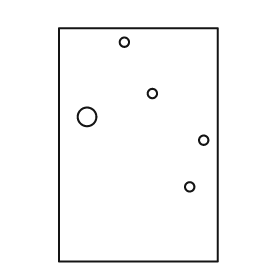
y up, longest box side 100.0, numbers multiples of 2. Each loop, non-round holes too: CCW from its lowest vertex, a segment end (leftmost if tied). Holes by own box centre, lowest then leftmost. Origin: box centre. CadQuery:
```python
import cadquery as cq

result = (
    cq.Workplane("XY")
    .moveTo(-34.0, -50.0)
    .lineTo(34.0, -50.0)
    .lineTo(34.0, 50.0)
    .lineTo(-34.0, 50.0)
    .close()
    .moveTo(22.0, -18.0)
    .circle(2.0)
    .moveTo(28.0, 2.0)
    .circle(2.0)
    .moveTo(-22.0, 12.0)
    .circle(4.0)
    .moveTo(6.0, 22.0)
    .circle(2.0)
    .moveTo(-6.0, 44.0)
    .circle(2.0)
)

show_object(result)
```